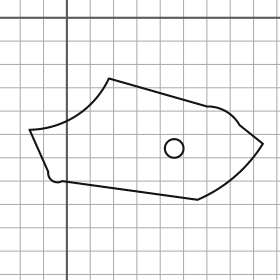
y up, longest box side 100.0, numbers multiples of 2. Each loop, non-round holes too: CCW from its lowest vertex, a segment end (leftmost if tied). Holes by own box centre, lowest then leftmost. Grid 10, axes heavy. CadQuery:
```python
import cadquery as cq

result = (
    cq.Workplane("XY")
    .moveTo(56.0, -78.0)
    .threePointArc((72.0, -68.0), (84.0, -54.0))
    .lineTo(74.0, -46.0)
    .threePointArc((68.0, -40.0), (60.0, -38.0))
    .lineTo(18.0, -26.0)
    .threePointArc((4.0, -42.0), (-16.0, -48.0))
    .lineTo(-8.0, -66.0)
    .threePointArc((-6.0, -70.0), (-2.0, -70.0))
    .close()
    .moveTo(46.0, -56.0)
    .circle(4.0)
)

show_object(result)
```